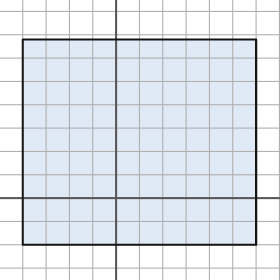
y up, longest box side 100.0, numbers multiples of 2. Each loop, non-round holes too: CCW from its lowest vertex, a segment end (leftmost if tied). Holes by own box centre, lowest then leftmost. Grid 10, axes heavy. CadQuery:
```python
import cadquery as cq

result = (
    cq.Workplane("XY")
    .moveTo(-40.0, -20.0)
    .lineTo(60.0, -20.0)
    .lineTo(60.0, 68.0)
    .lineTo(-40.0, 68.0)
    .close()
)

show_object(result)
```